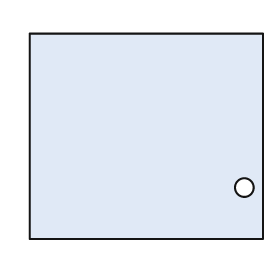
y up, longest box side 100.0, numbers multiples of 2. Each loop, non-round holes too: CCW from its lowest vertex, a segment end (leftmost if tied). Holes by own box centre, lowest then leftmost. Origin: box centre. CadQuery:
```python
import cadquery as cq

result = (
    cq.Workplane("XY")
    .moveTo(-50.0, -44.0)
    .lineTo(50.0, -44.0)
    .lineTo(50.0, 44.0)
    .lineTo(-50.0, 44.0)
    .close()
    .moveTo(42.0, -22.0)
    .circle(4.0)
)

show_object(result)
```